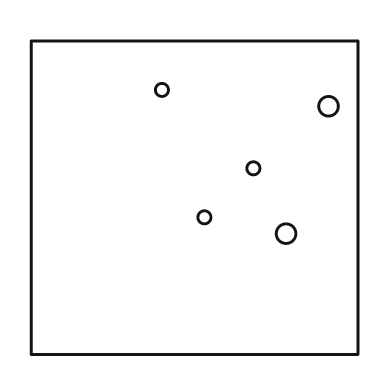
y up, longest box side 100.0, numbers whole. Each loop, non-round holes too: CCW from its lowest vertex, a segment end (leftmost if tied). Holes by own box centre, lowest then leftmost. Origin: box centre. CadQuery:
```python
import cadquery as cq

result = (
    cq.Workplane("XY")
    .moveTo(-50.0, -48.0)
    .lineTo(50.0, -48.0)
    .lineTo(50.0, 48.0)
    .lineTo(-50.0, 48.0)
    .close()
    .moveTo(28.0, -11.0)
    .circle(3.0)
    .moveTo(3.0, -6.0)
    .circle(2.0)
    .moveTo(18.0, 9.0)
    .circle(2.0)
    .moveTo(41.0, 28.0)
    .circle(3.0)
    .moveTo(-10.0, 33.0)
    .circle(2.0)
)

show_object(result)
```